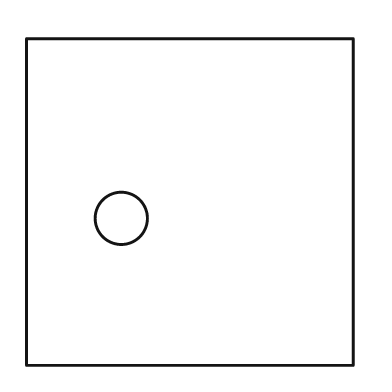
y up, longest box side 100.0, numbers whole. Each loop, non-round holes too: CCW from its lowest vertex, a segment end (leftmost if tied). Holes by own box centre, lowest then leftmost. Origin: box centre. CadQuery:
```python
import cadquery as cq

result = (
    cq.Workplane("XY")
    .moveTo(-50.0, -50.0)
    .lineTo(50.0, -50.0)
    .lineTo(50.0, 50.0)
    .lineTo(-50.0, 50.0)
    .close()
    .moveTo(-21.0, -5.0)
    .circle(8.0)
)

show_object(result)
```